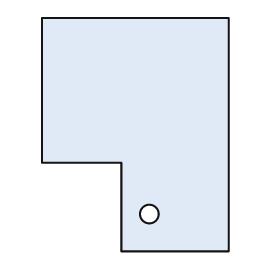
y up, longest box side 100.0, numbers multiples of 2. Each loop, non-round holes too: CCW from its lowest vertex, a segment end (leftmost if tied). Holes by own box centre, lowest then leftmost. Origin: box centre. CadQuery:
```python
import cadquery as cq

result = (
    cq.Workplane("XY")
    .moveTo(-6.0, -50.0)
    .lineTo(40.0, -50.0)
    .lineTo(40.0, 50.0)
    .lineTo(-40.0, 50.0)
    .lineTo(-40.0, -12.0)
    .lineTo(-6.0, -12.0)
    .close()
    .moveTo(6.0, -34.0)
    .circle(4.0)
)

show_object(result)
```